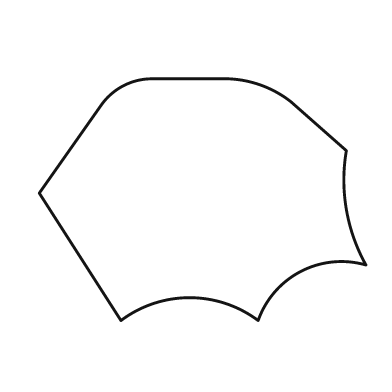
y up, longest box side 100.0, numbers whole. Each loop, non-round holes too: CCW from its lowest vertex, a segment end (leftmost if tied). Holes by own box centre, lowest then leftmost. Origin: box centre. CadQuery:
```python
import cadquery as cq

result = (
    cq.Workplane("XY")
    .moveTo(-25.0, -37.0)
    .threePointArc((-4.0, -30.0), (17.0, -37.0))
    .threePointArc((30.0, -22.0), (50.0, -20.0))
    .threePointArc((44.0, -3.0), (44.0, 15.0))
    .lineTo(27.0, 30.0)
    .threePointArc((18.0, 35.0), (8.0, 37.0))
    .lineTo(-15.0, 37.0)
    .threePointArc((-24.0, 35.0), (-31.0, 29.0))
    .lineTo(-50.0, 2.0)
    .close()
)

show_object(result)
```